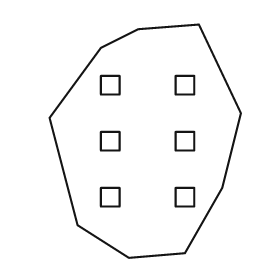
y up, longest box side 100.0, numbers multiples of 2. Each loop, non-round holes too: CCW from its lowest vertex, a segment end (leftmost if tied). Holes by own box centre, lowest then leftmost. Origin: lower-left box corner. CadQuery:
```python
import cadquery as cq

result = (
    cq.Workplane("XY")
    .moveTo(34.0, 0.0)
    .lineTo(58.0, 2.0)
    .lineTo(74.0, 30.0)
    .lineTo(82.0, 62.0)
    .lineTo(64.0, 100.0)
    .lineTo(38.0, 98.0)
    .lineTo(22.0, 90.0)
    .lineTo(0.0, 60.0)
    .lineTo(12.0, 14.0)
    .close()
    .moveTo(22.0, 22.0)
    .lineTo(30.0, 22.0)
    .lineTo(30.0, 30.0)
    .lineTo(22.0, 30.0)
    .close()
    .moveTo(54.0, 22.0)
    .lineTo(62.0, 22.0)
    .lineTo(62.0, 30.0)
    .lineTo(54.0, 30.0)
    .close()
    .moveTo(22.0, 46.0)
    .lineTo(30.0, 46.0)
    .lineTo(30.0, 54.0)
    .lineTo(22.0, 54.0)
    .close()
    .moveTo(54.0, 46.0)
    .lineTo(62.0, 46.0)
    .lineTo(62.0, 54.0)
    .lineTo(54.0, 54.0)
    .close()
    .moveTo(22.0, 70.0)
    .lineTo(30.0, 70.0)
    .lineTo(30.0, 78.0)
    .lineTo(22.0, 78.0)
    .close()
    .moveTo(54.0, 70.0)
    .lineTo(62.0, 70.0)
    .lineTo(62.0, 78.0)
    .lineTo(54.0, 78.0)
    .close()
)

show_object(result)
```